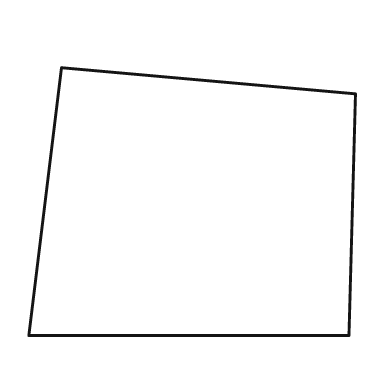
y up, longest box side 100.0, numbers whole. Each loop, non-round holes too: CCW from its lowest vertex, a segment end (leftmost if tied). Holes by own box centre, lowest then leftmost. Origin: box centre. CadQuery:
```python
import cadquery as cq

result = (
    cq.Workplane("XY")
    .moveTo(-50.0, -41.0)
    .lineTo(48.0, -41.0)
    .lineTo(50.0, 33.0)
    .lineTo(-40.0, 41.0)
    .close()
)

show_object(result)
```